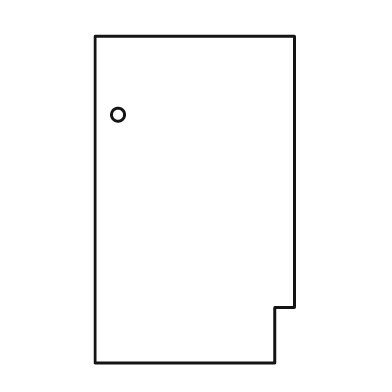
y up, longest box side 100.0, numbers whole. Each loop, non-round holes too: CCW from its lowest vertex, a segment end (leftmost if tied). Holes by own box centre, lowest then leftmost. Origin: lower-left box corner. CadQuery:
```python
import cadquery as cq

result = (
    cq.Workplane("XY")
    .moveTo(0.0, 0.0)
    .lineTo(55.0, 0.0)
    .lineTo(55.0, 17.0)
    .lineTo(61.0, 17.0)
    .lineTo(61.0, 100.0)
    .lineTo(0.0, 100.0)
    .close()
    .moveTo(7.0, 76.0)
    .circle(2.0)
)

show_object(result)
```